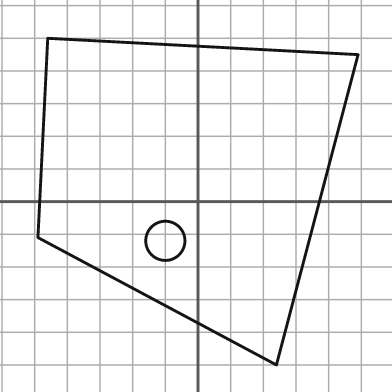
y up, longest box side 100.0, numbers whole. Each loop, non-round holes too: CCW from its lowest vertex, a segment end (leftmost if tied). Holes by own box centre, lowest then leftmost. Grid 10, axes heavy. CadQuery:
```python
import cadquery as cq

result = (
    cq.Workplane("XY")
    .moveTo(24.0, -50.0)
    .lineTo(49.0, 45.0)
    .lineTo(-46.0, 50.0)
    .lineTo(-49.0, -11.0)
    .close()
    .moveTo(-10.0, -12.0)
    .circle(6.0)
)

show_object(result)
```